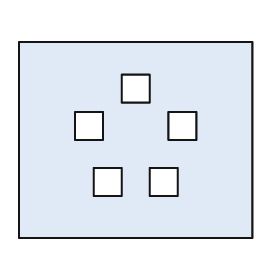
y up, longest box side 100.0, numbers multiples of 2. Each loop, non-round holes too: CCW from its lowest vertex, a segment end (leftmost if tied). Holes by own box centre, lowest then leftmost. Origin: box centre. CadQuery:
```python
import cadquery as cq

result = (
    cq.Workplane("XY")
    .moveTo(-50.0, -42.0)
    .lineTo(50.0, -42.0)
    .lineTo(50.0, 42.0)
    .lineTo(-50.0, 42.0)
    .close()
    .moveTo(-18.0, -24.0)
    .lineTo(-6.0, -24.0)
    .lineTo(-6.0, -12.0)
    .lineTo(-18.0, -12.0)
    .close()
    .moveTo(6.0, -24.0)
    .lineTo(18.0, -24.0)
    .lineTo(18.0, -12.0)
    .lineTo(6.0, -12.0)
    .close()
    .moveTo(-26.0, 0.0)
    .lineTo(-14.0, 0.0)
    .lineTo(-14.0, 12.0)
    .lineTo(-26.0, 12.0)
    .close()
    .moveTo(14.0, 0.0)
    .lineTo(26.0, 0.0)
    .lineTo(26.0, 12.0)
    .lineTo(14.0, 12.0)
    .close()
    .moveTo(-6.0, 16.0)
    .lineTo(6.0, 16.0)
    .lineTo(6.0, 28.0)
    .lineTo(-6.0, 28.0)
    .close()
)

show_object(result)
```